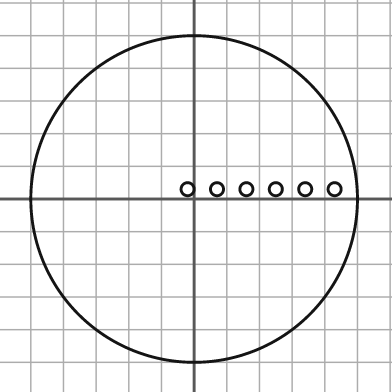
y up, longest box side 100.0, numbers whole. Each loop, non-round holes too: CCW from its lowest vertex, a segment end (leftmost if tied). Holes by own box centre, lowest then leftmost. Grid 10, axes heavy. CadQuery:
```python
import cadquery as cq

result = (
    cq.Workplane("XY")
    .moveTo(0.0, 0.0)
    .circle(50.0)
    .moveTo(-2.0, 3.0)
    .circle(2.0)
    .moveTo(7.0, 3.0)
    .circle(2.0)
    .moveTo(16.0, 3.0)
    .circle(2.0)
    .moveTo(25.0, 3.0)
    .circle(2.0)
    .moveTo(34.0, 3.0)
    .circle(2.0)
    .moveTo(43.0, 3.0)
    .circle(2.0)
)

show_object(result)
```